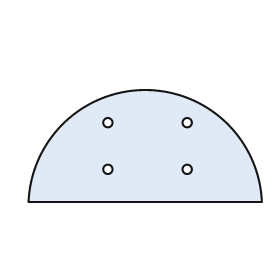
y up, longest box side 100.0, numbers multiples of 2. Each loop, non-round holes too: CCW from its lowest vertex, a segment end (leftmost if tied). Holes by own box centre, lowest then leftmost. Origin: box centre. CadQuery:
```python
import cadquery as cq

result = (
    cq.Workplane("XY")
    .moveTo(-50.0, -24.0)
    .lineTo(50.0, -24.0)
    .threePointArc((0.0, 24.0), (-50.0, -24.0))
    .close()
    .moveTo(-16.0, -10.0)
    .circle(2.0)
    .moveTo(18.0, -10.0)
    .circle(2.0)
    .moveTo(-16.0, 10.0)
    .circle(2.0)
    .moveTo(18.0, 10.0)
    .circle(2.0)
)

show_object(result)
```